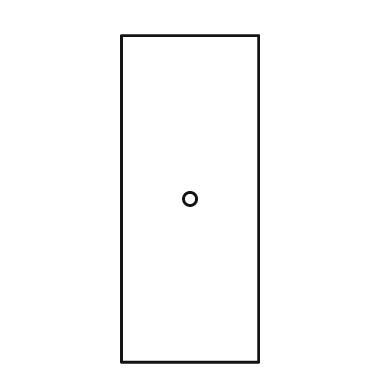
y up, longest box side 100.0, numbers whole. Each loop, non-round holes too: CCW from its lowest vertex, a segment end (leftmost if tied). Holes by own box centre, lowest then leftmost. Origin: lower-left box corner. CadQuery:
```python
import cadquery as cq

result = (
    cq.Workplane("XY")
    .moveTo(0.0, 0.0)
    .lineTo(42.0, 0.0)
    .lineTo(42.0, 100.0)
    .lineTo(0.0, 100.0)
    .close()
    .moveTo(21.0, 50.0)
    .circle(2.0)
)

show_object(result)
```